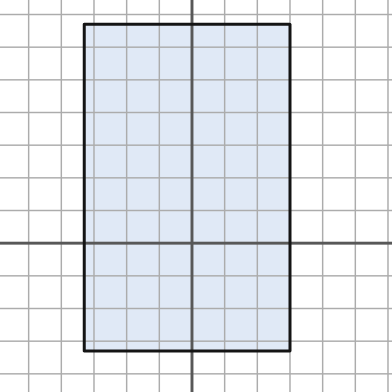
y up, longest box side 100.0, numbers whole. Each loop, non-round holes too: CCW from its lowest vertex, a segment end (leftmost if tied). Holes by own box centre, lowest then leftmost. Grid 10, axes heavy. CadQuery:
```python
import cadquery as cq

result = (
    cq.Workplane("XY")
    .moveTo(-33.0, -33.0)
    .lineTo(30.0, -33.0)
    .lineTo(30.0, 67.0)
    .lineTo(-33.0, 67.0)
    .close()
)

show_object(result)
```